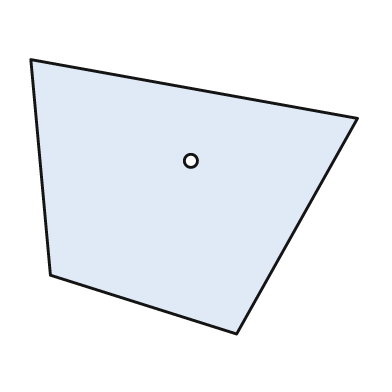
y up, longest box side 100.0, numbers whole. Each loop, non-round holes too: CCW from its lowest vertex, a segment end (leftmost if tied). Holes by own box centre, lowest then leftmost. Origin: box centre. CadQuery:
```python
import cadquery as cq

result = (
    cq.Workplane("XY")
    .moveTo(13.0, -42.0)
    .lineTo(50.0, 24.0)
    .lineTo(-50.0, 42.0)
    .lineTo(-44.0, -24.0)
    .close()
    .moveTo(-1.0, 11.0)
    .circle(2.0)
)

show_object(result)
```